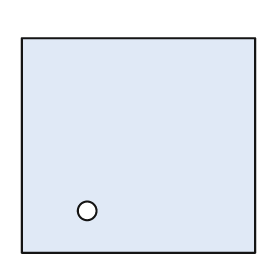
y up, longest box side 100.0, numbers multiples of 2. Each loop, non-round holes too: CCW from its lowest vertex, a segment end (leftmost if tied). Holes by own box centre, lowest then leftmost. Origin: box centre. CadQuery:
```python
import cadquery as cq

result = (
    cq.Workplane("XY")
    .moveTo(-50.0, -46.0)
    .lineTo(50.0, -46.0)
    .lineTo(50.0, 46.0)
    .lineTo(-50.0, 46.0)
    .close()
    .moveTo(-22.0, -28.0)
    .circle(4.0)
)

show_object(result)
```